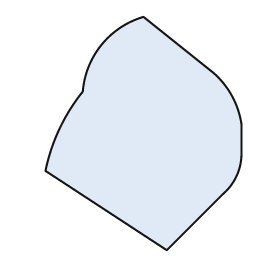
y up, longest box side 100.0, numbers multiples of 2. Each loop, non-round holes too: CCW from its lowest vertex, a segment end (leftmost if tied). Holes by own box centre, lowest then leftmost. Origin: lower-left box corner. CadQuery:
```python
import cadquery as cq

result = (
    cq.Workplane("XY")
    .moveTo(52.0, 0.0)
    .lineTo(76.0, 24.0)
    .threePointArc((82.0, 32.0), (84.0, 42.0))
    .lineTo(84.0, 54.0)
    .threePointArc((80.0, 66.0), (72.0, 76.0))
    .lineTo(42.0, 100.0)
    .threePointArc((24.0, 88.0), (16.0, 68.0))
    .threePointArc((6.0, 52.0), (0.0, 34.0))
    .close()
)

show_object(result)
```